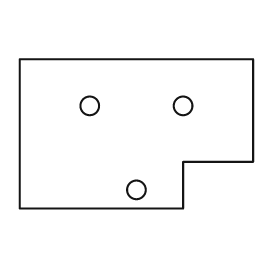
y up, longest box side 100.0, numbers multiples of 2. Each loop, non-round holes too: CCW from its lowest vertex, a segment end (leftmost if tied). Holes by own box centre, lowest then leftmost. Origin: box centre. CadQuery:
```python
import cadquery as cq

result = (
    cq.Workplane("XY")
    .moveTo(-50.0, -32.0)
    .lineTo(20.0, -32.0)
    .lineTo(20.0, -12.0)
    .lineTo(50.0, -12.0)
    .lineTo(50.0, 32.0)
    .lineTo(-50.0, 32.0)
    .close()
    .moveTo(0.0, -24.0)
    .circle(4.0)
    .moveTo(-20.0, 12.0)
    .circle(4.0)
    .moveTo(20.0, 12.0)
    .circle(4.0)
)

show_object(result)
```